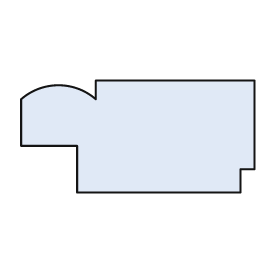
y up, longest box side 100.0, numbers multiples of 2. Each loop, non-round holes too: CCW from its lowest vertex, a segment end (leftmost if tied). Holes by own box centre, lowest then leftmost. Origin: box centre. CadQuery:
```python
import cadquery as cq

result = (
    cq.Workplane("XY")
    .moveTo(-26.0, -24.0)
    .lineTo(44.0, -24.0)
    .lineTo(44.0, -14.0)
    .lineTo(50.0, -14.0)
    .lineTo(50.0, 24.0)
    .lineTo(-18.0, 24.0)
    .lineTo(-18.0, 16.0)
    .threePointArc((-34.0, 22.0), (-50.0, 16.0))
    .lineTo(-50.0, -4.0)
    .lineTo(-26.0, -4.0)
    .close()
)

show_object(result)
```